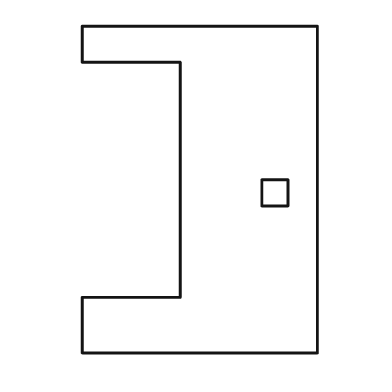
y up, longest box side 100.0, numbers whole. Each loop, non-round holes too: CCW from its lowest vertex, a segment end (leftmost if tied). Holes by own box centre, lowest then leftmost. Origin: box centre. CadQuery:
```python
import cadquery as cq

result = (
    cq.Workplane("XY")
    .moveTo(-36.0, -50.0)
    .lineTo(36.0, -50.0)
    .lineTo(36.0, 50.0)
    .lineTo(-36.0, 50.0)
    .lineTo(-36.0, 39.0)
    .lineTo(-6.0, 39.0)
    .lineTo(-6.0, -33.0)
    .lineTo(-36.0, -33.0)
    .close()
    .moveTo(19.0, -5.0)
    .lineTo(27.0, -5.0)
    .lineTo(27.0, 3.0)
    .lineTo(19.0, 3.0)
    .close()
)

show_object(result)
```